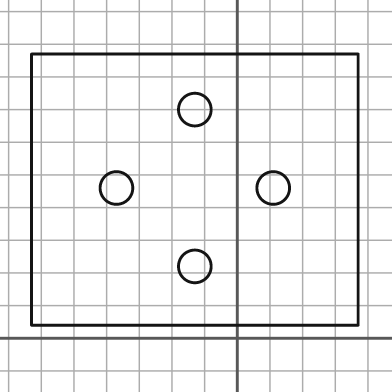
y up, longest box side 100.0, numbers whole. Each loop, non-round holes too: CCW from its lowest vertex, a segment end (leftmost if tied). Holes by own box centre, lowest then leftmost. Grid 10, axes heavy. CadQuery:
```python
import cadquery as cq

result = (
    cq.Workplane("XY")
    .moveTo(-63.0, 4.0)
    .lineTo(37.0, 4.0)
    .lineTo(37.0, 87.0)
    .lineTo(-63.0, 87.0)
    .close()
    .moveTo(-13.0, 22.0)
    .circle(5.0)
    .moveTo(-37.0, 46.0)
    .circle(5.0)
    .moveTo(11.0, 46.0)
    .circle(5.0)
    .moveTo(-13.0, 70.0)
    .circle(5.0)
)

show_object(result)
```